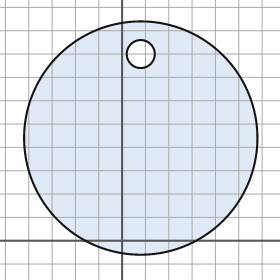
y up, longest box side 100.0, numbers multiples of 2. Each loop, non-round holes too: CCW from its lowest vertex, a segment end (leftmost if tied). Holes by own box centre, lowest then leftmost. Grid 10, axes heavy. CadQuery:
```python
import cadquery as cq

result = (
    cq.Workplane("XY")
    .moveTo(8.0, 44.0)
    .circle(50.0)
    .moveTo(8.0, 80.0)
    .circle(6.0)
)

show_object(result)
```